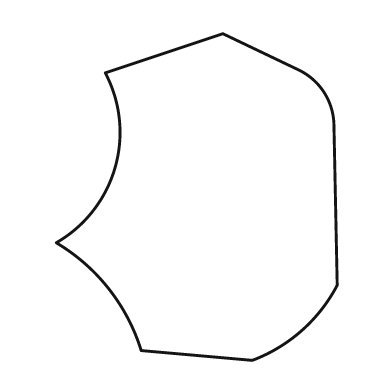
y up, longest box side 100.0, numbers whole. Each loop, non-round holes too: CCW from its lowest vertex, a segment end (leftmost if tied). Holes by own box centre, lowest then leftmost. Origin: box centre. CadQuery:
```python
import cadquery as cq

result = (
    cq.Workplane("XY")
    .moveTo(17.0, -50.0)
    .threePointArc((32.0, -41.0), (43.0, -27.0))
    .lineTo(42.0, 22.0)
    .threePointArc((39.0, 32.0), (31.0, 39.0))
    .lineTo(8.0, 50.0)
    .lineTo(-28.0, 38.0)
    .threePointArc((-25.0, 9.0), (-43.0, -14.0))
    .threePointArc((-27.0, -28.0), (-17.0, -47.0))
    .close()
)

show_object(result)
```